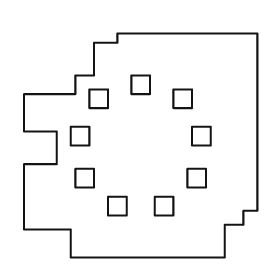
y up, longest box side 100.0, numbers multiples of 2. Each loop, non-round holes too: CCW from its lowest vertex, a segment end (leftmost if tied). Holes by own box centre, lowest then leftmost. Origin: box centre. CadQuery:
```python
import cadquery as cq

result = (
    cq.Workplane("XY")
    .moveTo(-30.0, -48.0)
    .lineTo(36.0, -48.0)
    .lineTo(36.0, -34.0)
    .lineTo(44.0, -34.0)
    .lineTo(44.0, -28.0)
    .lineTo(50.0, -28.0)
    .lineTo(50.0, 48.0)
    .lineTo(-10.0, 48.0)
    .lineTo(-10.0, 44.0)
    .lineTo(-20.0, 44.0)
    .lineTo(-20.0, 30.0)
    .lineTo(-28.0, 30.0)
    .lineTo(-28.0, 22.0)
    .lineTo(-50.0, 22.0)
    .lineTo(-50.0, 6.0)
    .lineTo(-36.0, 6.0)
    .lineTo(-36.0, -8.0)
    .lineTo(-50.0, -8.0)
    .lineTo(-50.0, -36.0)
    .lineTo(-30.0, -36.0)
    .close()
    .moveTo(-14.0, -30.0)
    .lineTo(-6.0, -30.0)
    .lineTo(-6.0, -22.0)
    .lineTo(-14.0, -22.0)
    .close()
    .moveTo(6.0, -30.0)
    .lineTo(14.0, -30.0)
    .lineTo(14.0, -22.0)
    .lineTo(6.0, -22.0)
    .close()
    .moveTo(-28.0, -18.0)
    .lineTo(-20.0, -18.0)
    .lineTo(-20.0, -10.0)
    .lineTo(-28.0, -10.0)
    .close()
    .moveTo(20.0, -18.0)
    .lineTo(28.0, -18.0)
    .lineTo(28.0, -10.0)
    .lineTo(20.0, -10.0)
    .close()
    .moveTo(-30.0, 0.0)
    .lineTo(-22.0, 0.0)
    .lineTo(-22.0, 8.0)
    .lineTo(-30.0, 8.0)
    .close()
    .moveTo(22.0, 0.0)
    .lineTo(30.0, 0.0)
    .lineTo(30.0, 8.0)
    .lineTo(22.0, 8.0)
    .close()
    .moveTo(-22.0, 16.0)
    .lineTo(-14.0, 16.0)
    .lineTo(-14.0, 24.0)
    .lineTo(-22.0, 24.0)
    .close()
    .moveTo(14.0, 16.0)
    .lineTo(22.0, 16.0)
    .lineTo(22.0, 24.0)
    .lineTo(14.0, 24.0)
    .close()
    .moveTo(-4.0, 22.0)
    .lineTo(4.0, 22.0)
    .lineTo(4.0, 30.0)
    .lineTo(-4.0, 30.0)
    .close()
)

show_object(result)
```